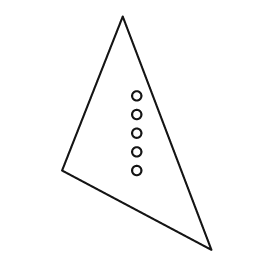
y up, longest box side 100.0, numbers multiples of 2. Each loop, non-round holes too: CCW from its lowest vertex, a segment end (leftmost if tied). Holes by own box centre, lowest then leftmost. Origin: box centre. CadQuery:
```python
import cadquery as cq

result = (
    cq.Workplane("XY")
    .moveTo(32.0, -50.0)
    .lineTo(-6.0, 50.0)
    .lineTo(-32.0, -16.0)
    .close()
    .moveTo(0.0, -16.0)
    .circle(2.0)
    .moveTo(0.0, -8.0)
    .circle(2.0)
    .moveTo(0.0, 0.0)
    .circle(2.0)
    .moveTo(0.0, 8.0)
    .circle(2.0)
    .moveTo(0.0, 16.0)
    .circle(2.0)
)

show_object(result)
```